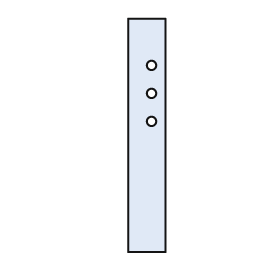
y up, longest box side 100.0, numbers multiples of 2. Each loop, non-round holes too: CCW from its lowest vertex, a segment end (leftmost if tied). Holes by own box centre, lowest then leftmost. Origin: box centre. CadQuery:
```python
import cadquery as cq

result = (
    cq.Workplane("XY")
    .moveTo(-8.0, -50.0)
    .lineTo(8.0, -50.0)
    .lineTo(8.0, 50.0)
    .lineTo(-8.0, 50.0)
    .close()
    .moveTo(2.0, 6.0)
    .circle(2.0)
    .moveTo(2.0, 18.0)
    .circle(2.0)
    .moveTo(2.0, 30.0)
    .circle(2.0)
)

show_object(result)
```